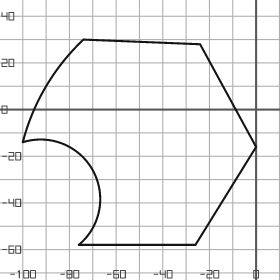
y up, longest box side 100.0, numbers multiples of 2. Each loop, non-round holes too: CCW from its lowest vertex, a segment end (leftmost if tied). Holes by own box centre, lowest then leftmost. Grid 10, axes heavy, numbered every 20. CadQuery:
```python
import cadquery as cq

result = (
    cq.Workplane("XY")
    .moveTo(-76.0, -58.0)
    .lineTo(-26.0, -58.0)
    .lineTo(0.0, -16.0)
    .lineTo(-24.0, 28.0)
    .lineTo(-74.0, 30.0)
    .threePointArc((-90.0, 10.0), (-100.0, -14.0))
    .threePointArc((-70.0, -26.0), (-76.0, -58.0))
    .close()
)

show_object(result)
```